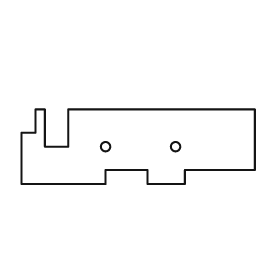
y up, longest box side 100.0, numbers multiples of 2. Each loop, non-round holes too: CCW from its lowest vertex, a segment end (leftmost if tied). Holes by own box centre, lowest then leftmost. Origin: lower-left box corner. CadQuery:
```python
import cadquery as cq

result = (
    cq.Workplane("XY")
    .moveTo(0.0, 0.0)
    .lineTo(36.0, 0.0)
    .lineTo(36.0, 6.0)
    .lineTo(54.0, 6.0)
    .lineTo(54.0, 0.0)
    .lineTo(70.0, 0.0)
    .lineTo(70.0, 6.0)
    .lineTo(100.0, 6.0)
    .lineTo(100.0, 32.0)
    .lineTo(20.0, 32.0)
    .lineTo(20.0, 16.0)
    .lineTo(10.0, 16.0)
    .lineTo(10.0, 32.0)
    .lineTo(6.0, 32.0)
    .lineTo(6.0, 22.0)
    .lineTo(0.0, 22.0)
    .close()
    .moveTo(36.0, 16.0)
    .circle(2.0)
    .moveTo(66.0, 16.0)
    .circle(2.0)
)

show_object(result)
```